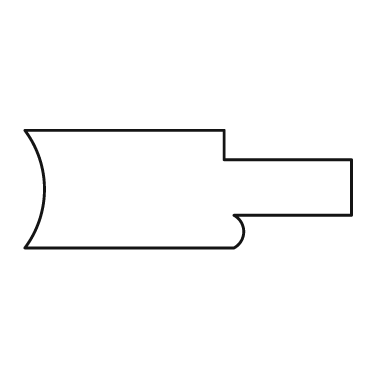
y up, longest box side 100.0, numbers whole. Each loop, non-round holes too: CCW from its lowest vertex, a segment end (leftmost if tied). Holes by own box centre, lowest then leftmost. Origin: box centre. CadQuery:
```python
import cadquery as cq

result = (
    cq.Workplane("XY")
    .moveTo(-50.0, -18.0)
    .lineTo(14.0, -18.0)
    .threePointArc((17.0, -13.0), (14.0, -8.0))
    .lineTo(50.0, -8.0)
    .lineTo(50.0, 9.0)
    .lineTo(11.0, 9.0)
    .lineTo(11.0, 18.0)
    .lineTo(-50.0, 18.0)
    .threePointArc((-44.0, 0.0), (-50.0, -18.0))
    .close()
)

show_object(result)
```